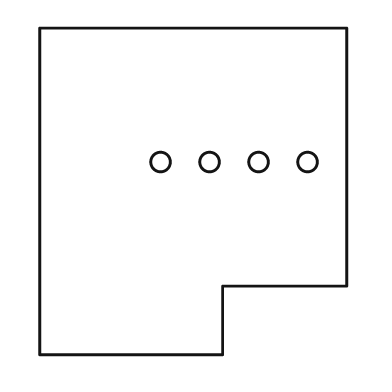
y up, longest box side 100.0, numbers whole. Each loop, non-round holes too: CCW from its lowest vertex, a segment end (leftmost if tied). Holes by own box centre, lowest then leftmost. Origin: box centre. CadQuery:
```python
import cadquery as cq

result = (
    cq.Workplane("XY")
    .moveTo(-47.0, -50.0)
    .lineTo(9.0, -50.0)
    .lineTo(9.0, -29.0)
    .lineTo(47.0, -29.0)
    .lineTo(47.0, 50.0)
    .lineTo(-47.0, 50.0)
    .close()
    .moveTo(-10.0, 9.0)
    .circle(3.0)
    .moveTo(5.0, 9.0)
    .circle(3.0)
    .moveTo(20.0, 9.0)
    .circle(3.0)
    .moveTo(35.0, 9.0)
    .circle(3.0)
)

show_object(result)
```